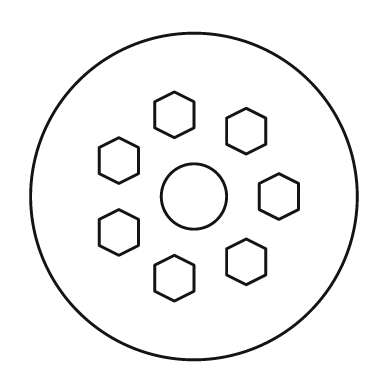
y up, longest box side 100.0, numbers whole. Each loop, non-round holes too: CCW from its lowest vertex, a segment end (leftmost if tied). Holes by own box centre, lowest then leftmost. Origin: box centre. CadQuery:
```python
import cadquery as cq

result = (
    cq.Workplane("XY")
    .moveTo(0.0, 0.0)
    .circle(50.0)
    .moveTo(-6.0, -32.0)
    .lineTo(0.0, -29.0)
    .lineTo(0.0, -21.0)
    .lineTo(-6.0, -18.0)
    .lineTo(-12.0, -21.0)
    .lineTo(-12.0, -29.0)
    .close()
    .moveTo(16.0, -27.0)
    .lineTo(22.0, -24.0)
    .lineTo(22.0, -16.0)
    .lineTo(16.0, -13.0)
    .lineTo(10.0, -16.0)
    .lineTo(10.0, -24.0)
    .close()
    .moveTo(-23.0, -18.0)
    .lineTo(-17.0, -15.0)
    .lineTo(-17.0, -7.0)
    .lineTo(-23.0, -4.0)
    .lineTo(-29.0, -7.0)
    .lineTo(-29.0, -15.0)
    .close()
    .moveTo(0.0, 0.0)
    .circle(10.0)
    .moveTo(26.0, -7.0)
    .lineTo(32.0, -4.0)
    .lineTo(32.0, 4.0)
    .lineTo(26.0, 7.0)
    .lineTo(20.0, 4.0)
    .lineTo(20.0, -4.0)
    .close()
    .moveTo(-23.0, 4.0)
    .lineTo(-17.0, 7.0)
    .lineTo(-17.0, 15.0)
    .lineTo(-23.0, 18.0)
    .lineTo(-29.0, 15.0)
    .lineTo(-29.0, 7.0)
    .close()
    .moveTo(16.0, 13.0)
    .lineTo(22.0, 16.0)
    .lineTo(22.0, 24.0)
    .lineTo(16.0, 27.0)
    .lineTo(10.0, 24.0)
    .lineTo(10.0, 16.0)
    .close()
    .moveTo(-6.0, 18.0)
    .lineTo(0.0, 21.0)
    .lineTo(0.0, 29.0)
    .lineTo(-6.0, 32.0)
    .lineTo(-12.0, 29.0)
    .lineTo(-12.0, 21.0)
    .close()
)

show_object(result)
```